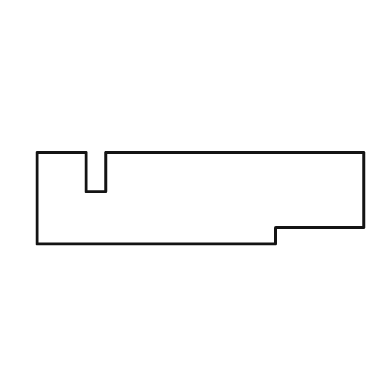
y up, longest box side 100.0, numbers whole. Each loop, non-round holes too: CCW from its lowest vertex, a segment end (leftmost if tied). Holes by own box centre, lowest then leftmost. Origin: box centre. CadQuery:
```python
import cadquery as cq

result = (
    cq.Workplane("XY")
    .moveTo(-50.0, -14.0)
    .lineTo(23.0, -14.0)
    .lineTo(23.0, -9.0)
    .lineTo(50.0, -9.0)
    .lineTo(50.0, 14.0)
    .lineTo(-29.0, 14.0)
    .lineTo(-29.0, 2.0)
    .lineTo(-35.0, 2.0)
    .lineTo(-35.0, 14.0)
    .lineTo(-50.0, 14.0)
    .close()
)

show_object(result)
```